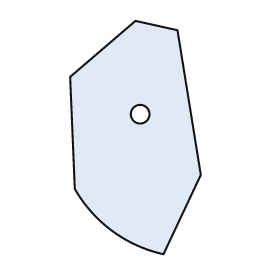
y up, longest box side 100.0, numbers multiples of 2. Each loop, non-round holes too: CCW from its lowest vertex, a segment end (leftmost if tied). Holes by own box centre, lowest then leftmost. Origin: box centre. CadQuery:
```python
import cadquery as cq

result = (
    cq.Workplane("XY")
    .moveTo(12.0, -50.0)
    .lineTo(28.0, -16.0)
    .lineTo(18.0, 46.0)
    .lineTo(0.0, 50.0)
    .lineTo(-28.0, 26.0)
    .lineTo(-26.0, -22.0)
    .threePointArc((-10.0, -40.0), (12.0, -50.0))
    .close()
    .moveTo(2.0, 10.0)
    .circle(4.0)
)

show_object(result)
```